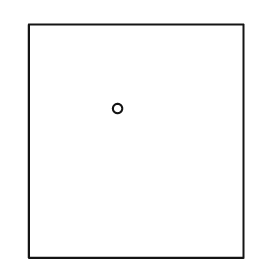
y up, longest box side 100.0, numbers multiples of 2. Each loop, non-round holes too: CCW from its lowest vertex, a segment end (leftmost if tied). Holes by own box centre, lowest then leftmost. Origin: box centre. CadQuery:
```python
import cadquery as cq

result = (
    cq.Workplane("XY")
    .moveTo(-46.0, -50.0)
    .lineTo(46.0, -50.0)
    .lineTo(46.0, 50.0)
    .lineTo(-46.0, 50.0)
    .close()
    .moveTo(-8.0, 14.0)
    .circle(2.0)
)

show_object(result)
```